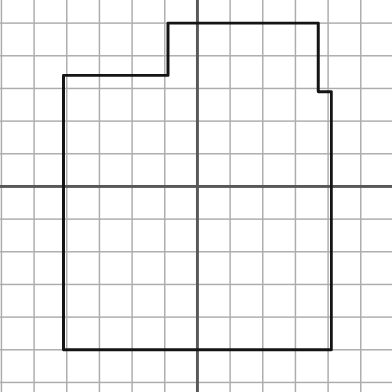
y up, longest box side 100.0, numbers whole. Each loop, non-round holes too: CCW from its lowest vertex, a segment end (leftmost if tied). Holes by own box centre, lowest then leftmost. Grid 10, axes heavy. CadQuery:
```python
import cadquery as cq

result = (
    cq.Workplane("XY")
    .moveTo(-41.0, -50.0)
    .lineTo(41.0, -50.0)
    .lineTo(41.0, 29.0)
    .lineTo(37.0, 29.0)
    .lineTo(37.0, 50.0)
    .lineTo(-9.0, 50.0)
    .lineTo(-9.0, 34.0)
    .lineTo(-41.0, 34.0)
    .close()
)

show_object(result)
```